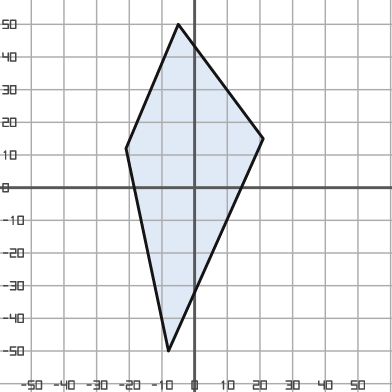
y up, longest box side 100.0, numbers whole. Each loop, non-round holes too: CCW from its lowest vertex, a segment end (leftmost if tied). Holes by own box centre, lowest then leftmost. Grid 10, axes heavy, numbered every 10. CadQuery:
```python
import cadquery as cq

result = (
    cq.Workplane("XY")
    .moveTo(-8.0, -50.0)
    .lineTo(21.0, 15.0)
    .lineTo(-5.0, 50.0)
    .lineTo(-21.0, 12.0)
    .close()
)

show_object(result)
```